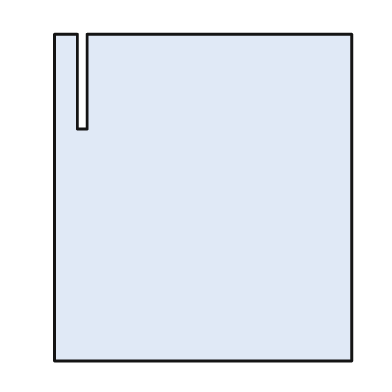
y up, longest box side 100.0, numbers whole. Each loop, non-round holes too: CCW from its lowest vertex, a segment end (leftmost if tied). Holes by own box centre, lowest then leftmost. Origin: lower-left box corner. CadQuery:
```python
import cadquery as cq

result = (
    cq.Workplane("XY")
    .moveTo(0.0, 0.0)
    .lineTo(91.0, 0.0)
    .lineTo(91.0, 100.0)
    .lineTo(10.0, 100.0)
    .lineTo(10.0, 71.0)
    .lineTo(7.0, 71.0)
    .lineTo(7.0, 100.0)
    .lineTo(0.0, 100.0)
    .close()
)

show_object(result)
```